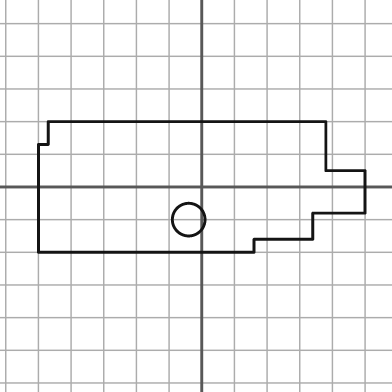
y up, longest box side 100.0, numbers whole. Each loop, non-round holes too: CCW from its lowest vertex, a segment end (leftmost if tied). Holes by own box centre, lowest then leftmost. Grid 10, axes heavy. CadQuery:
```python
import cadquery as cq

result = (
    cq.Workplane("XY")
    .moveTo(-50.0, -20.0)
    .lineTo(16.0, -20.0)
    .lineTo(16.0, -16.0)
    .lineTo(34.0, -16.0)
    .lineTo(34.0, -8.0)
    .lineTo(50.0, -8.0)
    .lineTo(50.0, 5.0)
    .lineTo(38.0, 5.0)
    .lineTo(38.0, 20.0)
    .lineTo(-47.0, 20.0)
    .lineTo(-47.0, 13.0)
    .lineTo(-50.0, 13.0)
    .close()
    .moveTo(-4.0, -10.0)
    .circle(5.0)
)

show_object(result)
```